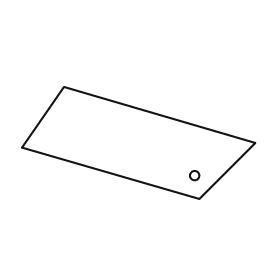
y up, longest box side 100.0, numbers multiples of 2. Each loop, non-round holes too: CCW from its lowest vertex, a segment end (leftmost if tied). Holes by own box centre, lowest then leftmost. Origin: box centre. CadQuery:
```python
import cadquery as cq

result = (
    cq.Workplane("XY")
    .moveTo(26.0, -24.0)
    .lineTo(50.0, 0.0)
    .lineTo(-32.0, 24.0)
    .lineTo(-50.0, -2.0)
    .close()
    .moveTo(24.0, -14.0)
    .circle(2.0)
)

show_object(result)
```